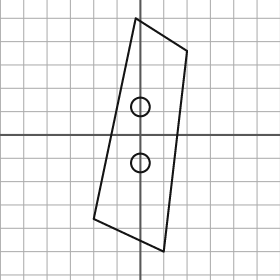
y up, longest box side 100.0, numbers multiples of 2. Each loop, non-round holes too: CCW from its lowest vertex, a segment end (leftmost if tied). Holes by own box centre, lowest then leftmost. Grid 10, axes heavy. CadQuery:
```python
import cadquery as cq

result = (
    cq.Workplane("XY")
    .moveTo(10.0, -50.0)
    .lineTo(20.0, 36.0)
    .lineTo(-2.0, 50.0)
    .lineTo(-20.0, -36.0)
    .close()
    .moveTo(0.0, -12.0)
    .circle(4.0)
    .moveTo(0.0, 12.0)
    .circle(4.0)
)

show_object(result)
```